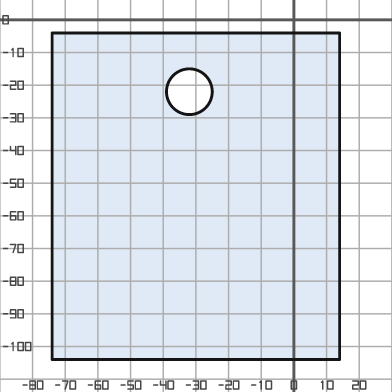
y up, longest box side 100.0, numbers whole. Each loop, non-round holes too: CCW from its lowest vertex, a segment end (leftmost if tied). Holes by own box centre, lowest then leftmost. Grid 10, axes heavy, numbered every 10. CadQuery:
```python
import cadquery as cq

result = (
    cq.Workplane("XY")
    .moveTo(-74.0, -104.0)
    .lineTo(14.0, -104.0)
    .lineTo(14.0, -4.0)
    .lineTo(-74.0, -4.0)
    .close()
    .moveTo(-32.0, -22.0)
    .circle(7.0)
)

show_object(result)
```